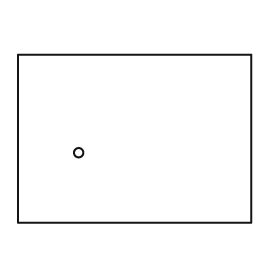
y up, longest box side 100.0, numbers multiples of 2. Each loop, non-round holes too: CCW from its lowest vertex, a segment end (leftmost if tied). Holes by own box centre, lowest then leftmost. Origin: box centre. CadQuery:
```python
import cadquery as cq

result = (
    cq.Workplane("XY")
    .moveTo(-50.0, -36.0)
    .lineTo(50.0, -36.0)
    .lineTo(50.0, 36.0)
    .lineTo(-50.0, 36.0)
    .close()
    .moveTo(-24.0, -6.0)
    .circle(2.0)
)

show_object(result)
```